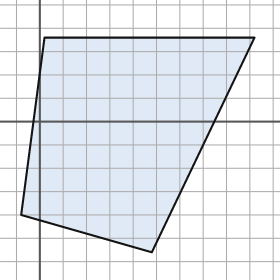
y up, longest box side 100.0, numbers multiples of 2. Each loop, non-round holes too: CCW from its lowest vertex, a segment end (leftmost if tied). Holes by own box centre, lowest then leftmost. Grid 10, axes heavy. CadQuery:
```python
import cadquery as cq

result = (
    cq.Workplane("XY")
    .moveTo(48.0, -56.0)
    .lineTo(92.0, 36.0)
    .lineTo(2.0, 36.0)
    .lineTo(-8.0, -40.0)
    .close()
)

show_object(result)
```